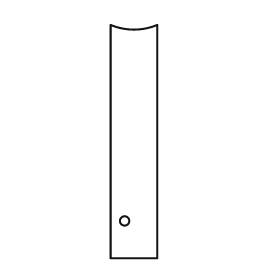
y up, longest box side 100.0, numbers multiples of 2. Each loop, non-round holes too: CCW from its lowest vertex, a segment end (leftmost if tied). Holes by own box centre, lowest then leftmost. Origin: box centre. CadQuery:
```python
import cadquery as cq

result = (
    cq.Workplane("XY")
    .moveTo(-10.0, -50.0)
    .lineTo(10.0, -50.0)
    .lineTo(10.0, 50.0)
    .threePointArc((0.0, 48.0), (-10.0, 50.0))
    .close()
    .moveTo(-4.0, -34.0)
    .circle(2.0)
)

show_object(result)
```